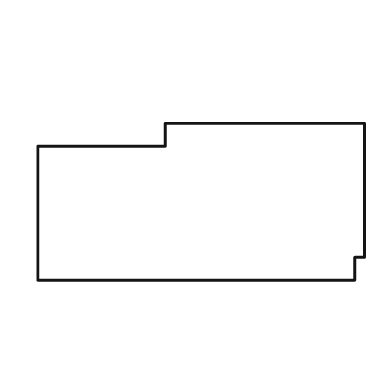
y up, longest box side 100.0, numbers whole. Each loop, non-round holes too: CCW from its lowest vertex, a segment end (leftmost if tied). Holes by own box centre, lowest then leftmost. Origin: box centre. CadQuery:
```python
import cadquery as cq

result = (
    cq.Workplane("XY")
    .moveTo(-50.0, -24.0)
    .lineTo(47.0, -24.0)
    .lineTo(47.0, -17.0)
    .lineTo(50.0, -17.0)
    .lineTo(50.0, 24.0)
    .lineTo(-11.0, 24.0)
    .lineTo(-11.0, 17.0)
    .lineTo(-50.0, 17.0)
    .close()
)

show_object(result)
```